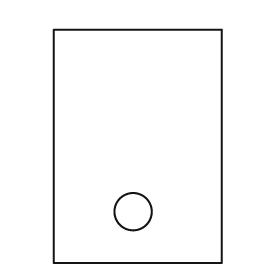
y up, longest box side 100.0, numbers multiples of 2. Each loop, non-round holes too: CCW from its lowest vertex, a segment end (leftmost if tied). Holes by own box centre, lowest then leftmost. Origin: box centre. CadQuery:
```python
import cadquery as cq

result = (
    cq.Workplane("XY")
    .moveTo(-36.0, -50.0)
    .lineTo(36.0, -50.0)
    .lineTo(36.0, 50.0)
    .lineTo(-36.0, 50.0)
    .close()
    .moveTo(-2.0, -28.0)
    .circle(8.0)
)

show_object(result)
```